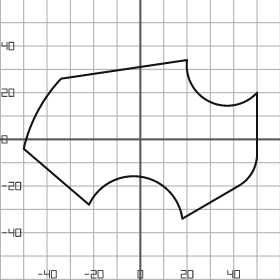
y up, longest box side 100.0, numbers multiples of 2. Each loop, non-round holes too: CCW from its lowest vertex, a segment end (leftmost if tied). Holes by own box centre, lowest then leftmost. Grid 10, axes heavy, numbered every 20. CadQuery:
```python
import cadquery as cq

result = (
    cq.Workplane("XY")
    .moveTo(18.0, -34.0)
    .lineTo(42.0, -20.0)
    .threePointArc((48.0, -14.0), (50.0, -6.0))
    .lineTo(50.0, 20.0)
    .threePointArc((30.0, 16.0), (20.0, 34.0))
    .lineTo(-34.0, 26.0)
    .threePointArc((-44.0, 12.0), (-50.0, -4.0))
    .lineTo(-22.0, -28.0)
    .threePointArc((0.0, -16.0), (18.0, -34.0))
    .close()
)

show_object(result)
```